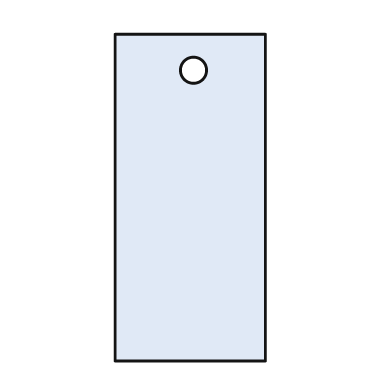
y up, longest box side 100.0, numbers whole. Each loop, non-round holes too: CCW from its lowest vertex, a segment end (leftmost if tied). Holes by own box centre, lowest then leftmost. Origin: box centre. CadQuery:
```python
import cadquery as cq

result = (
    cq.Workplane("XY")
    .moveTo(-23.0, -50.0)
    .lineTo(23.0, -50.0)
    .lineTo(23.0, 50.0)
    .lineTo(-23.0, 50.0)
    .close()
    .moveTo(1.0, 39.0)
    .circle(4.0)
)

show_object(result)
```